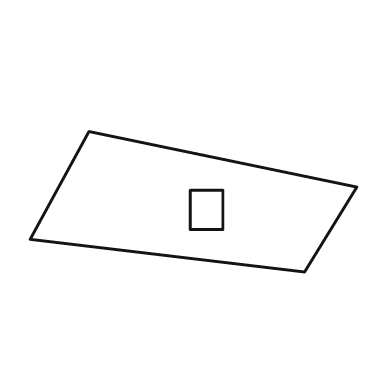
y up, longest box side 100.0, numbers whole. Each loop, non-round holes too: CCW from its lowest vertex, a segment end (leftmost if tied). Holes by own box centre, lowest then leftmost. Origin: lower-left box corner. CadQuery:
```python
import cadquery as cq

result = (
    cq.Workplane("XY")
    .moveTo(84.0, 0.0)
    .lineTo(100.0, 26.0)
    .lineTo(18.0, 43.0)
    .lineTo(0.0, 10.0)
    .close()
    .moveTo(49.0, 13.0)
    .lineTo(59.0, 13.0)
    .lineTo(59.0, 25.0)
    .lineTo(49.0, 25.0)
    .close()
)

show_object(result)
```